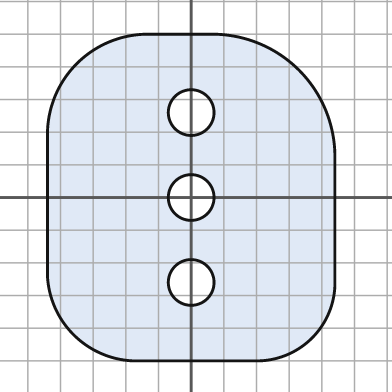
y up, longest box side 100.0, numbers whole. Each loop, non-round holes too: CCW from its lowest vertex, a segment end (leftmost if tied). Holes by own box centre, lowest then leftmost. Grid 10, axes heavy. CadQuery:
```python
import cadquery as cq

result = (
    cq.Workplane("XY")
    .moveTo(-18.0, -50.0)
    .lineTo(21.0, -50.0)
    .threePointArc((37.0, -43.0), (44.0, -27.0))
    .lineTo(44.0, 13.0)
    .threePointArc((33.0, 39.0), (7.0, 50.0))
    .lineTo(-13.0, 50.0)
    .threePointArc((-35.0, 41.0), (-44.0, 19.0))
    .lineTo(-44.0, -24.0)
    .threePointArc((-36.0, -42.0), (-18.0, -50.0))
    .close()
    .moveTo(0.0, -26.0)
    .circle(7.0)
    .moveTo(0.0, 0.0)
    .circle(7.0)
    .moveTo(0.0, 26.0)
    .circle(7.0)
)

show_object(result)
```